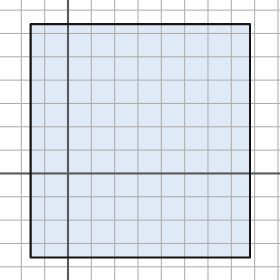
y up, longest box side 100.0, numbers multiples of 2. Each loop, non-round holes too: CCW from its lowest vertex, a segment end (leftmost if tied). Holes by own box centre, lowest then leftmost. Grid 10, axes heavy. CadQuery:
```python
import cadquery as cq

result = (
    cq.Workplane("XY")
    .moveTo(-16.0, -36.0)
    .lineTo(78.0, -36.0)
    .lineTo(78.0, 64.0)
    .lineTo(-16.0, 64.0)
    .close()
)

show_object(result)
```